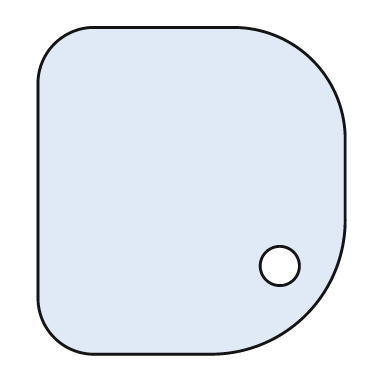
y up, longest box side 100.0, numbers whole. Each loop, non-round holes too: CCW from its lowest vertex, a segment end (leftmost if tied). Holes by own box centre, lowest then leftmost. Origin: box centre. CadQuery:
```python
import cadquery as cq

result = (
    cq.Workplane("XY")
    .moveTo(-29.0, -50.0)
    .lineTo(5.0, -50.0)
    .threePointArc((35.0, -38.0), (47.0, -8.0))
    .lineTo(47.0, 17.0)
    .threePointArc((37.0, 40.0), (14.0, 50.0))
    .lineTo(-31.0, 50.0)
    .threePointArc((-42.0, 45.0), (-47.0, 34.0))
    .lineTo(-47.0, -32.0)
    .threePointArc((-42.0, -45.0), (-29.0, -50.0))
    .close()
    .moveTo(27.0, -23.0)
    .circle(6.0)
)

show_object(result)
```